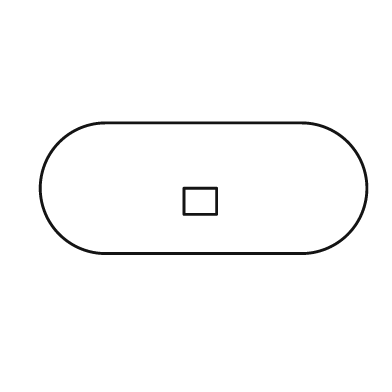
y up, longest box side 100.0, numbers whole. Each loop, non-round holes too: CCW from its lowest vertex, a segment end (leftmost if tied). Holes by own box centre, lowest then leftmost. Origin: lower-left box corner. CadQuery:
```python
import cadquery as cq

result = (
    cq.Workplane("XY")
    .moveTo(20.0, 0.0)
    .lineTo(80.0, 0.0)
    .threePointArc((100.0, 20.0), (80.0, 40.0))
    .lineTo(20.0, 40.0)
    .threePointArc((0.0, 20.0), (20.0, 0.0))
    .close()
    .moveTo(44.0, 12.0)
    .lineTo(54.0, 12.0)
    .lineTo(54.0, 20.0)
    .lineTo(44.0, 20.0)
    .close()
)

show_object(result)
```